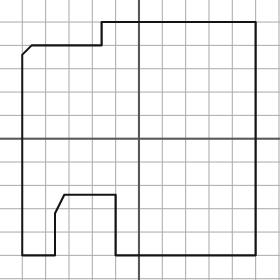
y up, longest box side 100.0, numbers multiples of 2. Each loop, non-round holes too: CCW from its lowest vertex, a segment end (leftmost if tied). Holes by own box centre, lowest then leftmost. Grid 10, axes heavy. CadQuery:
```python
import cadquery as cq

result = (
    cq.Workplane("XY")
    .moveTo(-50.0, -50.0)
    .lineTo(-36.0, -50.0)
    .lineTo(-36.0, -32.0)
    .lineTo(-32.0, -24.0)
    .lineTo(-10.0, -24.0)
    .lineTo(-10.0, -50.0)
    .lineTo(50.0, -50.0)
    .lineTo(50.0, 50.0)
    .lineTo(-16.0, 50.0)
    .lineTo(-16.0, 40.0)
    .lineTo(-46.0, 40.0)
    .lineTo(-50.0, 36.0)
    .close()
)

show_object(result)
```